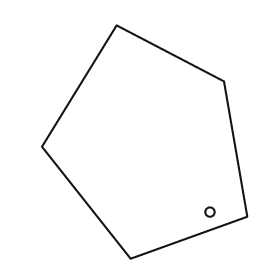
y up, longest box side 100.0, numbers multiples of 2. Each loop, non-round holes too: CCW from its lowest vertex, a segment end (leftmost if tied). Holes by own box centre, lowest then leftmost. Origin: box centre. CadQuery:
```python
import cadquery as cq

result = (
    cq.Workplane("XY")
    .moveTo(-6.0, -50.0)
    .lineTo(44.0, -32.0)
    .lineTo(34.0, 26.0)
    .lineTo(-12.0, 50.0)
    .lineTo(-44.0, -2.0)
    .close()
    .moveTo(28.0, -30.0)
    .circle(2.0)
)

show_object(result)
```